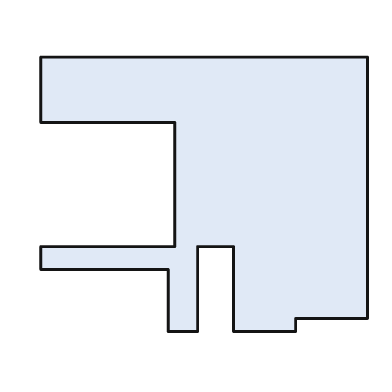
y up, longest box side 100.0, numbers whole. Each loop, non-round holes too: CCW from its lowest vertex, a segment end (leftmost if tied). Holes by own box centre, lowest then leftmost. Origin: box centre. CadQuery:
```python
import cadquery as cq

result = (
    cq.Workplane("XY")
    .moveTo(-11.0, -42.0)
    .lineTo(-2.0, -42.0)
    .lineTo(-2.0, -16.0)
    .lineTo(9.0, -16.0)
    .lineTo(9.0, -42.0)
    .lineTo(28.0, -42.0)
    .lineTo(28.0, -38.0)
    .lineTo(50.0, -38.0)
    .lineTo(50.0, 42.0)
    .lineTo(-50.0, 42.0)
    .lineTo(-50.0, 22.0)
    .lineTo(-9.0, 22.0)
    .lineTo(-9.0, -16.0)
    .lineTo(-50.0, -16.0)
    .lineTo(-50.0, -23.0)
    .lineTo(-11.0, -23.0)
    .close()
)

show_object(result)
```